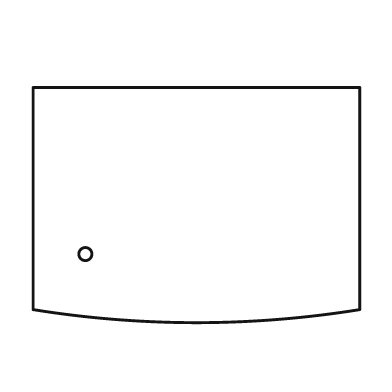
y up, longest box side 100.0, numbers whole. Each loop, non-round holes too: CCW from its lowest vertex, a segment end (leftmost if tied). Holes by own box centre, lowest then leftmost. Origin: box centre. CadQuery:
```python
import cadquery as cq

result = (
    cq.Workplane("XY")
    .moveTo(-50.0, -32.0)
    .threePointArc((0.0, -36.0), (50.0, -32.0))
    .lineTo(50.0, 36.0)
    .lineTo(-50.0, 36.0)
    .close()
    .moveTo(-34.0, -15.0)
    .circle(2.0)
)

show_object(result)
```